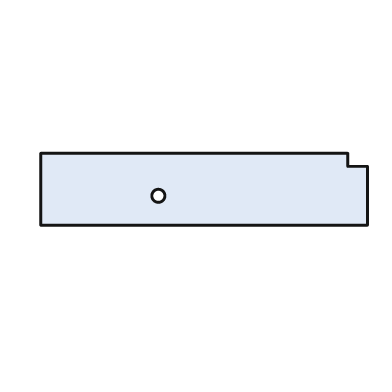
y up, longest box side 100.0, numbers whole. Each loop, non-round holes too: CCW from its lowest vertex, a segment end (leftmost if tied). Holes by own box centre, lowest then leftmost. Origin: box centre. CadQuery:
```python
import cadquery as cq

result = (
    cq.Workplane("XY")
    .moveTo(-50.0, -11.0)
    .lineTo(50.0, -11.0)
    .lineTo(50.0, 7.0)
    .lineTo(44.0, 7.0)
    .lineTo(44.0, 11.0)
    .lineTo(-50.0, 11.0)
    .close()
    .moveTo(-14.0, -2.0)
    .circle(2.0)
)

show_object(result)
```